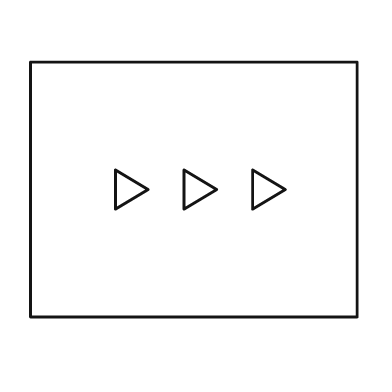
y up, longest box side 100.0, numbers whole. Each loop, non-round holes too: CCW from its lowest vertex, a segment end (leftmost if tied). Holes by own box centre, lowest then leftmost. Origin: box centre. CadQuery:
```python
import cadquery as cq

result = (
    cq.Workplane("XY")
    .moveTo(-50.0, -39.0)
    .lineTo(50.0, -39.0)
    .lineTo(50.0, 39.0)
    .lineTo(-50.0, 39.0)
    .close()
    .moveTo(-24.0, -6.0)
    .lineTo(-14.0, 0.0)
    .lineTo(-24.0, 6.0)
    .close()
    .moveTo(-3.0, -6.0)
    .lineTo(7.0, 0.0)
    .lineTo(-3.0, 6.0)
    .close()
    .moveTo(18.0, -6.0)
    .lineTo(28.0, 0.0)
    .lineTo(18.0, 6.0)
    .close()
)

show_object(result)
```